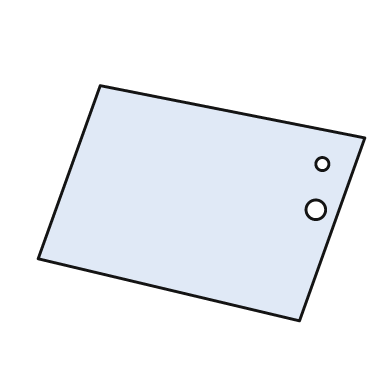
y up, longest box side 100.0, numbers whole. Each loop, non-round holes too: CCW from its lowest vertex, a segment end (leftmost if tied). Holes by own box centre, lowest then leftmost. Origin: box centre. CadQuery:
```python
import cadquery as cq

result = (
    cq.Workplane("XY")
    .moveTo(30.0, -36.0)
    .lineTo(50.0, 20.0)
    .lineTo(-31.0, 36.0)
    .lineTo(-50.0, -17.0)
    .close()
    .moveTo(35.0, -2.0)
    .circle(3.0)
    .moveTo(37.0, 12.0)
    .circle(2.0)
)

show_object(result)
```